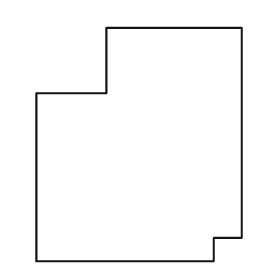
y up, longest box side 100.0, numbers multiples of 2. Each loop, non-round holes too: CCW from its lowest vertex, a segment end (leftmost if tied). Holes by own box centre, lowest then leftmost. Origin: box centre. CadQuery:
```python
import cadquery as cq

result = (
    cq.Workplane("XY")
    .moveTo(-44.0, -50.0)
    .lineTo(32.0, -50.0)
    .lineTo(32.0, -40.0)
    .lineTo(44.0, -40.0)
    .lineTo(44.0, 50.0)
    .lineTo(-14.0, 50.0)
    .lineTo(-14.0, 22.0)
    .lineTo(-44.0, 22.0)
    .close()
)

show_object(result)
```